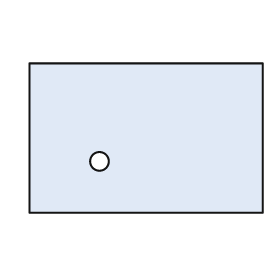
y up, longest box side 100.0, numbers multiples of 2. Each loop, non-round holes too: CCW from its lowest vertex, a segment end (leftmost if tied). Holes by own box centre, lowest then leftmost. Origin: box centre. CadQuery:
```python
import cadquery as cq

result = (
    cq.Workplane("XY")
    .moveTo(-50.0, -32.0)
    .lineTo(50.0, -32.0)
    .lineTo(50.0, 32.0)
    .lineTo(-50.0, 32.0)
    .close()
    .moveTo(-20.0, -10.0)
    .circle(4.0)
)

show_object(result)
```